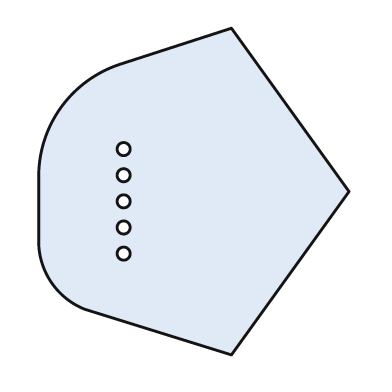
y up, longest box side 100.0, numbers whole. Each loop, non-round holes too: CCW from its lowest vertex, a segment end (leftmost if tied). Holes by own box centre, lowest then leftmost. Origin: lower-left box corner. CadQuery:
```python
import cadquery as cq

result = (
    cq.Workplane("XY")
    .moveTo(59.0, 0.0)
    .lineTo(95.0, 50.0)
    .lineTo(59.0, 100.0)
    .lineTo(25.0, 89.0)
    .threePointArc((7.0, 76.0), (0.0, 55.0))
    .lineTo(0.0, 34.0)
    .threePointArc((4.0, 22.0), (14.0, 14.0))
    .close()
    .moveTo(26.0, 31.0)
    .circle(2.0)
    .moveTo(26.0, 39.0)
    .circle(2.0)
    .moveTo(26.0, 47.0)
    .circle(2.0)
    .moveTo(26.0, 55.0)
    .circle(2.0)
    .moveTo(26.0, 63.0)
    .circle(2.0)
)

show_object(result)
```